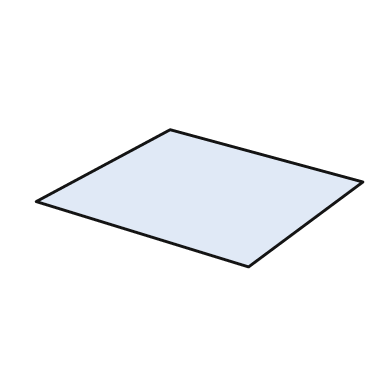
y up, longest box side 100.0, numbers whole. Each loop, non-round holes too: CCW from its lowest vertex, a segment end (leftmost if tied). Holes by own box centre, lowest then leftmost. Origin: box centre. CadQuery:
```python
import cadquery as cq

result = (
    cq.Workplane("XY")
    .moveTo(15.0, -21.0)
    .lineTo(50.0, 5.0)
    .lineTo(-9.0, 21.0)
    .lineTo(-50.0, -1.0)
    .close()
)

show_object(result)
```